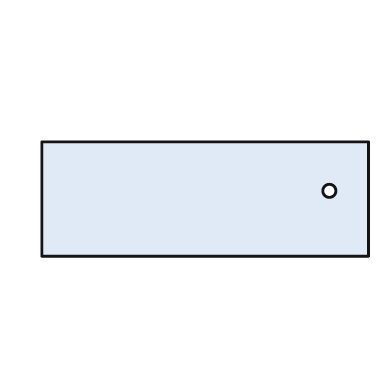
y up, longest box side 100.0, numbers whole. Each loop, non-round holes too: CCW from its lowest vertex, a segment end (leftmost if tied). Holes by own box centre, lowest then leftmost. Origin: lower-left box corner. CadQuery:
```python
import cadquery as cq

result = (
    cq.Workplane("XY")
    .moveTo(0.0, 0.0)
    .lineTo(100.0, 0.0)
    .lineTo(100.0, 35.0)
    .lineTo(0.0, 35.0)
    .close()
    .moveTo(88.0, 20.0)
    .circle(2.0)
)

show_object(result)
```